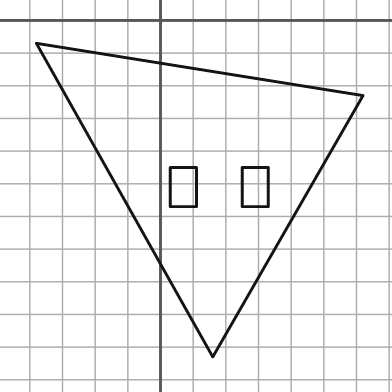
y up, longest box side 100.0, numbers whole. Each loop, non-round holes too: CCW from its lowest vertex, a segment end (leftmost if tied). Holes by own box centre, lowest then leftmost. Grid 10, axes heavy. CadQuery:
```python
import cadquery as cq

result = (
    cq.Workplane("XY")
    .moveTo(16.0, -103.0)
    .lineTo(62.0, -23.0)
    .lineTo(-38.0, -7.0)
    .close()
    .moveTo(3.0, -57.0)
    .lineTo(11.0, -57.0)
    .lineTo(11.0, -45.0)
    .lineTo(3.0, -45.0)
    .close()
    .moveTo(25.0, -57.0)
    .lineTo(33.0, -57.0)
    .lineTo(33.0, -45.0)
    .lineTo(25.0, -45.0)
    .close()
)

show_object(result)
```